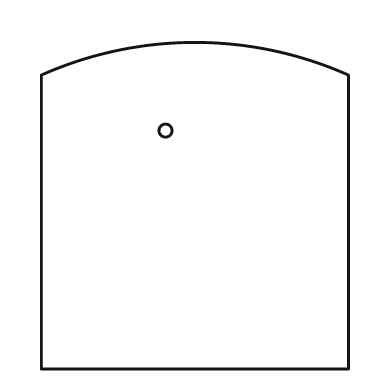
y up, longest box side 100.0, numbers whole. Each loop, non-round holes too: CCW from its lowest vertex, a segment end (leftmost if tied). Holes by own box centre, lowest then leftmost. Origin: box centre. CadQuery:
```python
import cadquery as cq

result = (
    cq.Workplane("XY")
    .moveTo(-47.0, -50.0)
    .lineTo(47.0, -50.0)
    .lineTo(47.0, 40.0)
    .threePointArc((0.0, 50.0), (-47.0, 40.0))
    .close()
    .moveTo(-9.0, 23.0)
    .circle(2.0)
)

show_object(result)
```